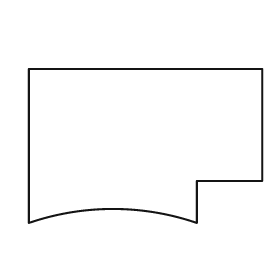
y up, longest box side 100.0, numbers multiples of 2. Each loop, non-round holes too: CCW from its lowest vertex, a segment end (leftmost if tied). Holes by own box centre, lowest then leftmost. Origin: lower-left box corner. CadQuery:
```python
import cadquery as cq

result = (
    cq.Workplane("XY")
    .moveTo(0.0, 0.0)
    .threePointArc((36.0, 6.0), (72.0, 0.0))
    .lineTo(72.0, 18.0)
    .lineTo(100.0, 18.0)
    .lineTo(100.0, 66.0)
    .lineTo(0.0, 66.0)
    .close()
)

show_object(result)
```